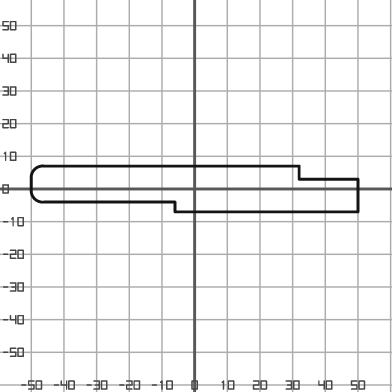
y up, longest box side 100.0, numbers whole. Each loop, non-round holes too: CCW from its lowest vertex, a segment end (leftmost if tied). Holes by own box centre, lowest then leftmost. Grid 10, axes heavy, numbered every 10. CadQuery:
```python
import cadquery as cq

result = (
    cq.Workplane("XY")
    .moveTo(-6.0, -7.0)
    .lineTo(50.0, -7.0)
    .lineTo(50.0, 3.0)
    .lineTo(32.0, 3.0)
    .lineTo(32.0, 7.0)
    .lineTo(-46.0, 7.0)
    .threePointArc((-49.0, 6.0), (-50.0, 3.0))
    .lineTo(-50.0, 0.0)
    .threePointArc((-49.0, -3.0), (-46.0, -4.0))
    .lineTo(-6.0, -4.0)
    .close()
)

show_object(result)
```